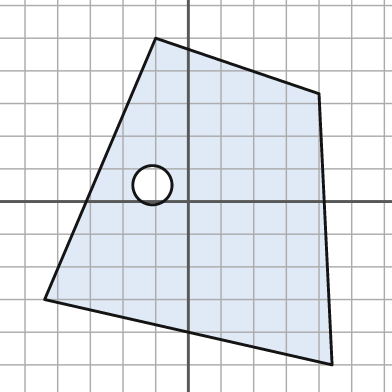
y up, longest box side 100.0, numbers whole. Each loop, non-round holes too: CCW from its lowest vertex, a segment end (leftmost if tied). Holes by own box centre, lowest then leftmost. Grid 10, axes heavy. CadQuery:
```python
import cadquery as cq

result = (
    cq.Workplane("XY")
    .moveTo(44.0, -50.0)
    .lineTo(40.0, 33.0)
    .lineTo(-10.0, 50.0)
    .lineTo(-44.0, -30.0)
    .close()
    .moveTo(-11.0, 5.0)
    .circle(6.0)
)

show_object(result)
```